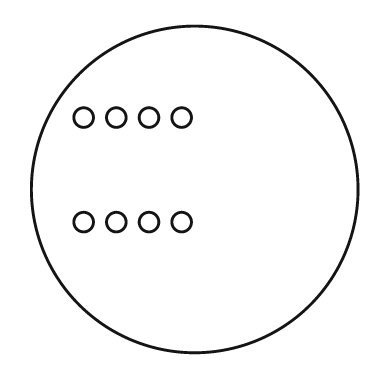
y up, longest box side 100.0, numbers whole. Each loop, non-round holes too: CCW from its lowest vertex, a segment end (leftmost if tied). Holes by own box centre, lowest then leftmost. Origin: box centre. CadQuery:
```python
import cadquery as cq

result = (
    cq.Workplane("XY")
    .moveTo(0.0, 0.0)
    .circle(50.0)
    .moveTo(-34.0, -10.0)
    .circle(3.0)
    .moveTo(-24.0, -10.0)
    .circle(3.0)
    .moveTo(-14.0, -10.0)
    .circle(3.0)
    .moveTo(-4.0, -10.0)
    .circle(3.0)
    .moveTo(-34.0, 22.0)
    .circle(3.0)
    .moveTo(-24.0, 22.0)
    .circle(3.0)
    .moveTo(-14.0, 22.0)
    .circle(3.0)
    .moveTo(-4.0, 22.0)
    .circle(3.0)
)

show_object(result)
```